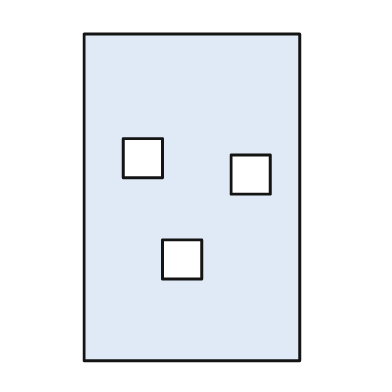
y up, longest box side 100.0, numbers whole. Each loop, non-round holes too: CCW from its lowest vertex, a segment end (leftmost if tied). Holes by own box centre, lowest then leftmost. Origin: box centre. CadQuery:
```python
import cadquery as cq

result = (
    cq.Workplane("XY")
    .moveTo(-33.0, -50.0)
    .lineTo(33.0, -50.0)
    .lineTo(33.0, 50.0)
    .lineTo(-33.0, 50.0)
    .close()
    .moveTo(-9.0, -25.0)
    .lineTo(3.0, -25.0)
    .lineTo(3.0, -13.0)
    .lineTo(-9.0, -13.0)
    .close()
    .moveTo(12.0, 1.0)
    .lineTo(24.0, 1.0)
    .lineTo(24.0, 13.0)
    .lineTo(12.0, 13.0)
    .close()
    .moveTo(-21.0, 6.0)
    .lineTo(-9.0, 6.0)
    .lineTo(-9.0, 18.0)
    .lineTo(-21.0, 18.0)
    .close()
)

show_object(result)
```